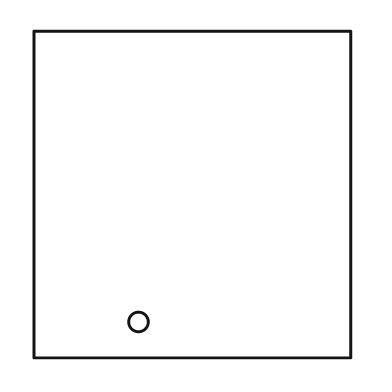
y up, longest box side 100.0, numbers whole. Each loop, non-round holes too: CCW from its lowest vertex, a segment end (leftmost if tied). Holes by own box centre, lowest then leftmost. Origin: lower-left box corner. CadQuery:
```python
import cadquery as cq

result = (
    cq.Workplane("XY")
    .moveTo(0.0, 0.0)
    .lineTo(97.0, 0.0)
    .lineTo(97.0, 100.0)
    .lineTo(0.0, 100.0)
    .close()
    .moveTo(32.0, 11.0)
    .circle(3.0)
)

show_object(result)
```